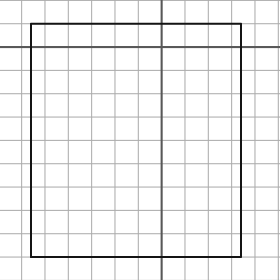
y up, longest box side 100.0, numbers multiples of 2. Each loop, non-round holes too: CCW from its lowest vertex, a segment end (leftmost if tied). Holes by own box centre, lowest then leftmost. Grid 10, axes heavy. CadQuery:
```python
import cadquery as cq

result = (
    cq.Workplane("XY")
    .moveTo(-56.0, -90.0)
    .lineTo(34.0, -90.0)
    .lineTo(34.0, 10.0)
    .lineTo(-56.0, 10.0)
    .close()
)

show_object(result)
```